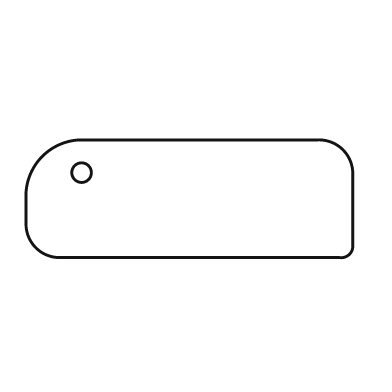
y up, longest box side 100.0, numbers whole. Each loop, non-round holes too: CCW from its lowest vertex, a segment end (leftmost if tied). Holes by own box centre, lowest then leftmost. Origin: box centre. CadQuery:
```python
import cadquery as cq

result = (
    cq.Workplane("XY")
    .moveTo(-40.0, -18.0)
    .lineTo(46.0, -18.0)
    .threePointArc((49.0, -17.0), (50.0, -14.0))
    .lineTo(50.0, 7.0)
    .threePointArc((47.0, 15.0), (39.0, 18.0))
    .lineTo(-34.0, 18.0)
    .threePointArc((-45.0, 13.0), (-50.0, 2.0))
    .lineTo(-50.0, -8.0)
    .threePointArc((-47.0, -15.0), (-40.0, -18.0))
    .close()
    .moveTo(-33.0, 8.0)
    .circle(3.0)
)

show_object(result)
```